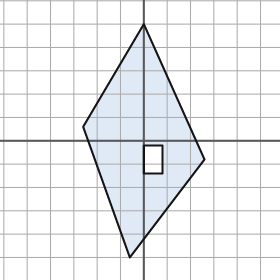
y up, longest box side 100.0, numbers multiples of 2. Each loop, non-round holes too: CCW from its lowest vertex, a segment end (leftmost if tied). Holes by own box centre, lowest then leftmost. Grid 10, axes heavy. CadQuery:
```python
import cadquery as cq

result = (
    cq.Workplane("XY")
    .moveTo(-6.0, -50.0)
    .lineTo(26.0, -8.0)
    .lineTo(0.0, 50.0)
    .lineTo(-26.0, 6.0)
    .close()
    .moveTo(0.0, -14.0)
    .lineTo(8.0, -14.0)
    .lineTo(8.0, -2.0)
    .lineTo(0.0, -2.0)
    .close()
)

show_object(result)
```